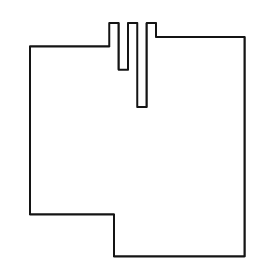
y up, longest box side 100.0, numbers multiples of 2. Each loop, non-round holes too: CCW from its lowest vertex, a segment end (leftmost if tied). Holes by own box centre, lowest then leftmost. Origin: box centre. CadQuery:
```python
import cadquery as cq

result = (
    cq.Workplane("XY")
    .moveTo(-10.0, -50.0)
    .lineTo(46.0, -50.0)
    .lineTo(46.0, 44.0)
    .lineTo(8.0, 44.0)
    .lineTo(8.0, 50.0)
    .lineTo(4.0, 50.0)
    .lineTo(4.0, 14.0)
    .lineTo(0.0, 14.0)
    .lineTo(0.0, 50.0)
    .lineTo(-4.0, 50.0)
    .lineTo(-4.0, 30.0)
    .lineTo(-8.0, 30.0)
    .lineTo(-8.0, 50.0)
    .lineTo(-12.0, 50.0)
    .lineTo(-12.0, 40.0)
    .lineTo(-46.0, 40.0)
    .lineTo(-46.0, -32.0)
    .lineTo(-10.0, -32.0)
    .close()
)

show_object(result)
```